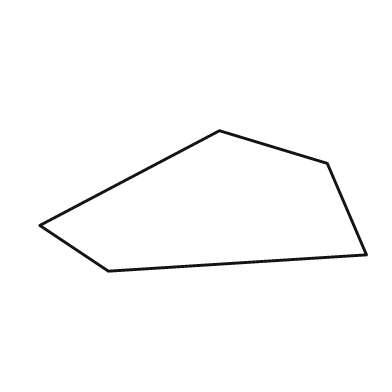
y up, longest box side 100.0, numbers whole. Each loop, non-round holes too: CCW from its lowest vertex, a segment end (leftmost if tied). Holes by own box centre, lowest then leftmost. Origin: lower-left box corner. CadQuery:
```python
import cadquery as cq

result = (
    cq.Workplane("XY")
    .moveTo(21.0, 0.0)
    .lineTo(100.0, 5.0)
    .lineTo(88.0, 33.0)
    .lineTo(55.0, 43.0)
    .lineTo(0.0, 14.0)
    .close()
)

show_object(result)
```